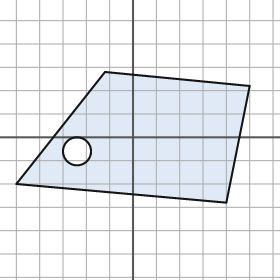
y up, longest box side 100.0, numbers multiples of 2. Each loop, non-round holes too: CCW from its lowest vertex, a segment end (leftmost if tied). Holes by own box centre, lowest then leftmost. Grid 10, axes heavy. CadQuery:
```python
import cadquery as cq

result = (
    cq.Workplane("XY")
    .moveTo(40.0, -28.0)
    .lineTo(50.0, 22.0)
    .lineTo(-12.0, 28.0)
    .lineTo(-50.0, -20.0)
    .close()
    .moveTo(-24.0, -6.0)
    .circle(6.0)
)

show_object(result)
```